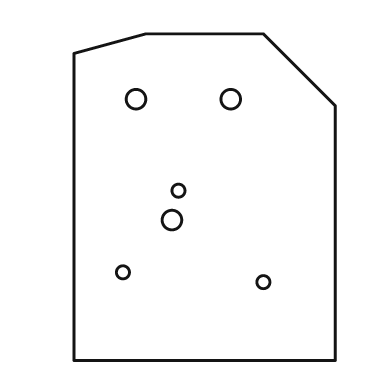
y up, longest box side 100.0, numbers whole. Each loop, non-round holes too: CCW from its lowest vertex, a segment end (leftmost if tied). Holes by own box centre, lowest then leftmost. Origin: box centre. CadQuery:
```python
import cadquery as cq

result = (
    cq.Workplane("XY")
    .moveTo(-40.0, -50.0)
    .lineTo(40.0, -50.0)
    .lineTo(40.0, 28.0)
    .lineTo(18.0, 50.0)
    .lineTo(-18.0, 50.0)
    .lineTo(-40.0, 44.0)
    .close()
    .moveTo(18.0, -26.0)
    .circle(2.0)
    .moveTo(-25.0, -23.0)
    .circle(2.0)
    .moveTo(-10.0, -7.0)
    .circle(3.0)
    .moveTo(-8.0, 2.0)
    .circle(2.0)
    .moveTo(-21.0, 30.0)
    .circle(3.0)
    .moveTo(8.0, 30.0)
    .circle(3.0)
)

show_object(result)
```